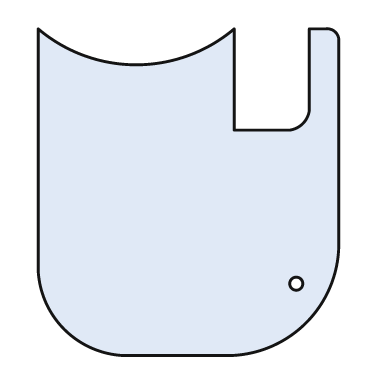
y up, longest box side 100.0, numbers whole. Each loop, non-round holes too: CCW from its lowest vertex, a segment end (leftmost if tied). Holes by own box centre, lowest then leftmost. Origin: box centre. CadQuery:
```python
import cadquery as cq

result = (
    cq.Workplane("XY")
    .moveTo(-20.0, -50.0)
    .lineTo(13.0, -50.0)
    .threePointArc((36.0, -40.0), (46.0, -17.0))
    .lineTo(46.0, 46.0)
    .threePointArc((45.0, 49.0), (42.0, 50.0))
    .lineTo(37.0, 50.0)
    .lineTo(37.0, 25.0)
    .threePointArc((35.0, 21.0), (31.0, 19.0))
    .lineTo(14.0, 19.0)
    .lineTo(14.0, 50.0)
    .threePointArc((-16.0, 39.0), (-46.0, 50.0))
    .lineTo(-46.0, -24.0)
    .threePointArc((-38.0, -42.0), (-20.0, -50.0))
    .close()
    .moveTo(33.0, -28.0)
    .circle(2.0)
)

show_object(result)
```